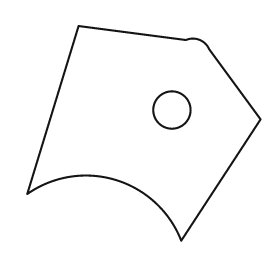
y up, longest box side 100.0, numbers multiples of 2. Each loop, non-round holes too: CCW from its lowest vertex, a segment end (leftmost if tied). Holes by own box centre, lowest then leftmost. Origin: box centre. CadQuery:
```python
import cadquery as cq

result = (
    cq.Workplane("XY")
    .moveTo(16.0, -46.0)
    .lineTo(50.0, 6.0)
    .lineTo(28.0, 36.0)
    .threePointArc((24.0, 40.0), (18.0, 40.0))
    .lineTo(-28.0, 46.0)
    .lineTo(-50.0, -26.0)
    .threePointArc((-12.0, -20.0), (16.0, -46.0))
    .close()
    .moveTo(12.0, 10.0)
    .circle(8.0)
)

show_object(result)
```